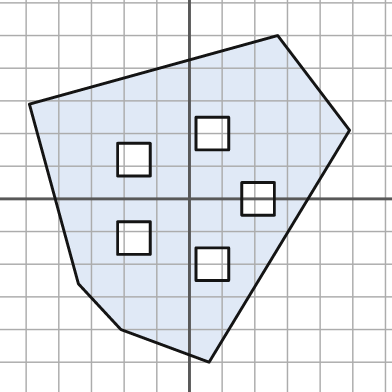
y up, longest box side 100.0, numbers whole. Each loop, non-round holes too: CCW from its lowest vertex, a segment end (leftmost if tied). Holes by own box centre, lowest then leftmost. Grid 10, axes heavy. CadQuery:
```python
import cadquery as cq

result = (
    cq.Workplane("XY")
    .moveTo(6.0, -50.0)
    .lineTo(49.0, 21.0)
    .lineTo(27.0, 50.0)
    .lineTo(-49.0, 29.0)
    .lineTo(-34.0, -26.0)
    .lineTo(-21.0, -40.0)
    .close()
    .moveTo(2.0, -25.0)
    .lineTo(12.0, -25.0)
    .lineTo(12.0, -15.0)
    .lineTo(2.0, -15.0)
    .close()
    .moveTo(-22.0, -17.0)
    .lineTo(-12.0, -17.0)
    .lineTo(-12.0, -7.0)
    .lineTo(-22.0, -7.0)
    .close()
    .moveTo(16.0, -5.0)
    .lineTo(26.0, -5.0)
    .lineTo(26.0, 5.0)
    .lineTo(16.0, 5.0)
    .close()
    .moveTo(-22.0, 7.0)
    .lineTo(-12.0, 7.0)
    .lineTo(-12.0, 17.0)
    .lineTo(-22.0, 17.0)
    .close()
    .moveTo(2.0, 15.0)
    .lineTo(12.0, 15.0)
    .lineTo(12.0, 25.0)
    .lineTo(2.0, 25.0)
    .close()
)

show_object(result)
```